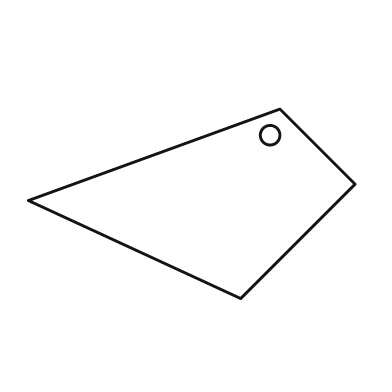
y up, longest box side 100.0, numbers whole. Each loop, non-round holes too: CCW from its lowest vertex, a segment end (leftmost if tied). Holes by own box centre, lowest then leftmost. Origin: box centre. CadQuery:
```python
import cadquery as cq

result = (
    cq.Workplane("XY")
    .moveTo(15.0, -29.0)
    .lineTo(50.0, 6.0)
    .lineTo(27.0, 29.0)
    .lineTo(-50.0, 1.0)
    .close()
    .moveTo(24.0, 21.0)
    .circle(3.0)
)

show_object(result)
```